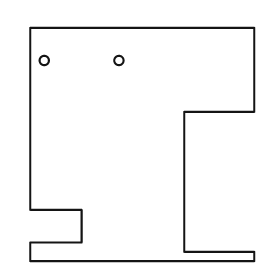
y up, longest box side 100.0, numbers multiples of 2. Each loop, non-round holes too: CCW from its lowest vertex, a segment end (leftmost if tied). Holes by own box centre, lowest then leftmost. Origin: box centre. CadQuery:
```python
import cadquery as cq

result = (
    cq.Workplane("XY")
    .moveTo(-48.0, -50.0)
    .lineTo(48.0, -50.0)
    .lineTo(48.0, -46.0)
    .lineTo(18.0, -46.0)
    .lineTo(18.0, 14.0)
    .lineTo(48.0, 14.0)
    .lineTo(48.0, 50.0)
    .lineTo(-48.0, 50.0)
    .lineTo(-48.0, -28.0)
    .lineTo(-26.0, -28.0)
    .lineTo(-26.0, -42.0)
    .lineTo(-48.0, -42.0)
    .close()
    .moveTo(-42.0, 36.0)
    .circle(2.0)
    .moveTo(-10.0, 36.0)
    .circle(2.0)
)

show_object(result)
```